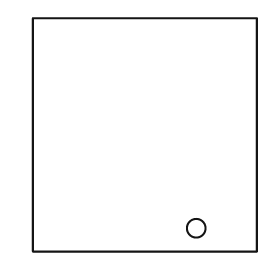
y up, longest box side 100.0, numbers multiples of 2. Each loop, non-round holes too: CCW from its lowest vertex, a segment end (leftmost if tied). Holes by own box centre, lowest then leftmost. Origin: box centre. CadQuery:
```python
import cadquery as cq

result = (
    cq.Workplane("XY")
    .moveTo(-48.0, -50.0)
    .lineTo(48.0, -50.0)
    .lineTo(48.0, 50.0)
    .lineTo(-48.0, 50.0)
    .close()
    .moveTo(22.0, -40.0)
    .circle(4.0)
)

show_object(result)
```